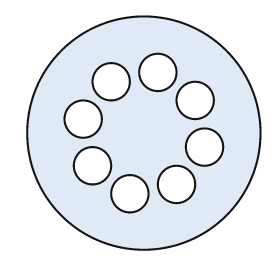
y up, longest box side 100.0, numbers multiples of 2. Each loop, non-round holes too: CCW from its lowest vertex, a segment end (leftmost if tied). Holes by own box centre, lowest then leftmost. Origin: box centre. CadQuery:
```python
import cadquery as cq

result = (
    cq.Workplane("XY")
    .moveTo(0.0, 0.0)
    .circle(50.0)
    .moveTo(-6.0, -26.0)
    .circle(8.0)
    .moveTo(14.0, -22.0)
    .circle(8.0)
    .moveTo(-22.0, -14.0)
    .circle(8.0)
    .moveTo(26.0, -6.0)
    .circle(8.0)
    .moveTo(-26.0, 6.0)
    .circle(8.0)
    .moveTo(22.0, 14.0)
    .circle(8.0)
    .moveTo(-14.0, 22.0)
    .circle(8.0)
    .moveTo(6.0, 26.0)
    .circle(8.0)
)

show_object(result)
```